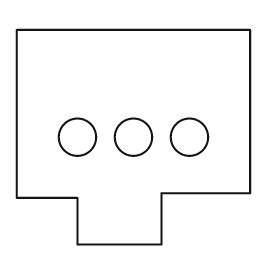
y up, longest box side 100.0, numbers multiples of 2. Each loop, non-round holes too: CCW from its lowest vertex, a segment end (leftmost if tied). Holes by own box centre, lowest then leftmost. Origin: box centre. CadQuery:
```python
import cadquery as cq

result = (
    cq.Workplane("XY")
    .moveTo(-24.0, -46.0)
    .lineTo(12.0, -46.0)
    .lineTo(12.0, -24.0)
    .lineTo(50.0, -24.0)
    .lineTo(50.0, 46.0)
    .lineTo(-50.0, 46.0)
    .lineTo(-50.0, -26.0)
    .lineTo(-24.0, -26.0)
    .close()
    .moveTo(-24.0, 0.0)
    .circle(8.0)
    .moveTo(0.0, 0.0)
    .circle(8.0)
    .moveTo(24.0, 0.0)
    .circle(8.0)
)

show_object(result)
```